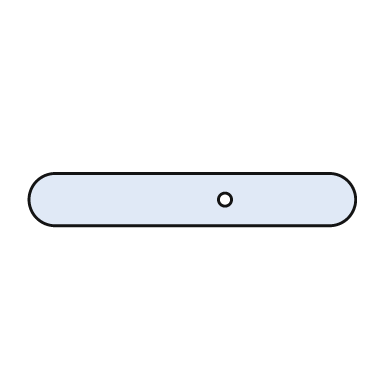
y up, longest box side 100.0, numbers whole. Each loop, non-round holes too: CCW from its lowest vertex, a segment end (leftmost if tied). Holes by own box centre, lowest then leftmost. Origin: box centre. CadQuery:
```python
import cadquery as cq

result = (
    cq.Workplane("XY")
    .moveTo(-42.0, -8.0)
    .lineTo(42.0, -8.0)
    .threePointArc((50.0, 0.0), (42.0, 8.0))
    .lineTo(-42.0, 8.0)
    .threePointArc((-50.0, 0.0), (-42.0, -8.0))
    .close()
    .moveTo(10.0, 0.0)
    .circle(2.0)
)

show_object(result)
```